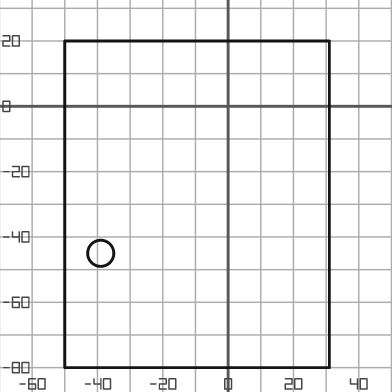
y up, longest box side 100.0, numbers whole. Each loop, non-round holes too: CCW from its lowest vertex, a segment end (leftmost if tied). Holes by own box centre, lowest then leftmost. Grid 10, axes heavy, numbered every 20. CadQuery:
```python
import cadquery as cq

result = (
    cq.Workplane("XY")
    .moveTo(-50.0, -80.0)
    .lineTo(31.0, -80.0)
    .lineTo(31.0, 20.0)
    .lineTo(-50.0, 20.0)
    .close()
    .moveTo(-39.0, -45.0)
    .circle(4.0)
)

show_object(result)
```